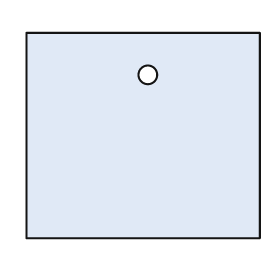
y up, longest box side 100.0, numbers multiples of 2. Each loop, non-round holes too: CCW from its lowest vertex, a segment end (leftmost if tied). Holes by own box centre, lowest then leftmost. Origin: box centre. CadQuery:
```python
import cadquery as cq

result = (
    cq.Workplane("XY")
    .moveTo(-50.0, -44.0)
    .lineTo(50.0, -44.0)
    .lineTo(50.0, 44.0)
    .lineTo(-50.0, 44.0)
    .close()
    .moveTo(2.0, 26.0)
    .circle(4.0)
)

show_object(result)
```